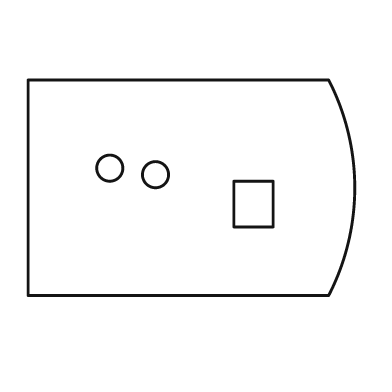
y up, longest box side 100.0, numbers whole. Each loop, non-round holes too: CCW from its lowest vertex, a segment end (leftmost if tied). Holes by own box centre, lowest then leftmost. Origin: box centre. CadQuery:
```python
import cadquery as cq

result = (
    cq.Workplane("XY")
    .moveTo(-50.0, -33.0)
    .lineTo(42.0, -33.0)
    .threePointArc((50.0, 0.0), (42.0, 33.0))
    .lineTo(-50.0, 33.0)
    .close()
    .moveTo(13.0, -12.0)
    .lineTo(25.0, -12.0)
    .lineTo(25.0, 2.0)
    .lineTo(13.0, 2.0)
    .close()
    .moveTo(-11.0, 4.0)
    .circle(4.0)
    .moveTo(-25.0, 6.0)
    .circle(4.0)
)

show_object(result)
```